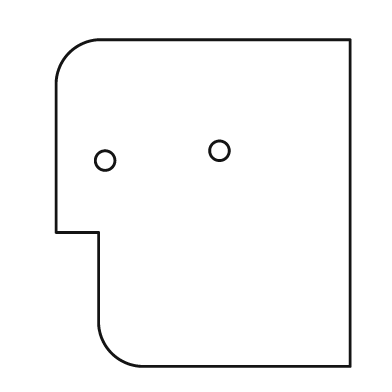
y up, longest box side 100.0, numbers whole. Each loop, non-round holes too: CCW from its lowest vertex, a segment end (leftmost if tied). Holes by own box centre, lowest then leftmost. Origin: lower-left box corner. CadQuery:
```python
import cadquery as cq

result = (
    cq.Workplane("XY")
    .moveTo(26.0, 0.0)
    .lineTo(90.0, 0.0)
    .lineTo(90.0, 100.0)
    .lineTo(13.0, 100.0)
    .threePointArc((4.0, 96.0), (0.0, 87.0))
    .lineTo(0.0, 41.0)
    .lineTo(13.0, 41.0)
    .lineTo(13.0, 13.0)
    .threePointArc((17.0, 4.0), (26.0, 0.0))
    .close()
    .moveTo(15.0, 63.0)
    .circle(3.0)
    .moveTo(50.0, 66.0)
    .circle(3.0)
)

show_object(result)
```